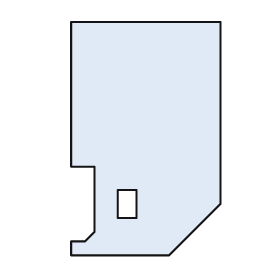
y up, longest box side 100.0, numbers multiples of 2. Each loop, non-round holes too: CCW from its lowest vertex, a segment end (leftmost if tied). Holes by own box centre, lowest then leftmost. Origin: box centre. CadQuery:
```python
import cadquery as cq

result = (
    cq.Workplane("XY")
    .moveTo(-32.0, -50.0)
    .lineTo(10.0, -50.0)
    .lineTo(32.0, -28.0)
    .lineTo(32.0, 50.0)
    .lineTo(-32.0, 50.0)
    .lineTo(-32.0, -12.0)
    .lineTo(-22.0, -12.0)
    .lineTo(-22.0, -40.0)
    .lineTo(-26.0, -44.0)
    .lineTo(-32.0, -44.0)
    .close()
    .moveTo(-12.0, -34.0)
    .lineTo(-4.0, -34.0)
    .lineTo(-4.0, -22.0)
    .lineTo(-12.0, -22.0)
    .close()
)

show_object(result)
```